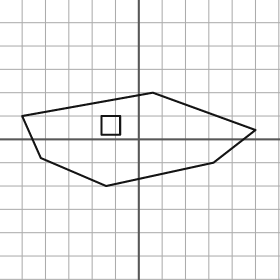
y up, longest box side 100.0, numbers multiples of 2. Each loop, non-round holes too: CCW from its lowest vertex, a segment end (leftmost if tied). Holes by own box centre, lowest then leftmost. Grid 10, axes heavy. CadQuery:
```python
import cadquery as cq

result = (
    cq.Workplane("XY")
    .moveTo(-14.0, -20.0)
    .lineTo(32.0, -10.0)
    .lineTo(50.0, 4.0)
    .lineTo(6.0, 20.0)
    .lineTo(-50.0, 10.0)
    .lineTo(-42.0, -8.0)
    .close()
    .moveTo(-16.0, 2.0)
    .lineTo(-8.0, 2.0)
    .lineTo(-8.0, 10.0)
    .lineTo(-16.0, 10.0)
    .close()
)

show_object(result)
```